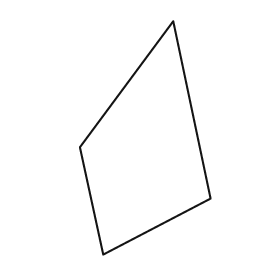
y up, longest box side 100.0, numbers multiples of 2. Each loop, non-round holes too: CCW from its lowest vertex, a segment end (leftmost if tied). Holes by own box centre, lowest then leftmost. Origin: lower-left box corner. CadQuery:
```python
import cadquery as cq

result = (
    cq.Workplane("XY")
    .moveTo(10.0, 0.0)
    .lineTo(56.0, 24.0)
    .lineTo(40.0, 100.0)
    .lineTo(0.0, 46.0)
    .close()
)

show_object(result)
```